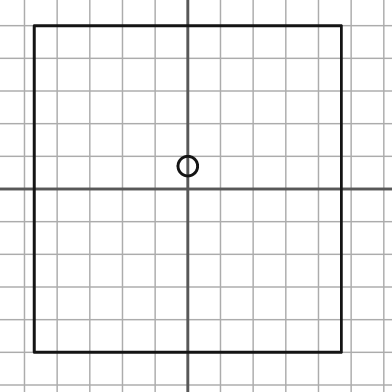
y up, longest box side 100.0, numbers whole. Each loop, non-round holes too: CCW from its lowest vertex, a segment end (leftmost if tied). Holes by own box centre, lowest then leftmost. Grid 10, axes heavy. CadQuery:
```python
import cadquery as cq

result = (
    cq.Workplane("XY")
    .moveTo(-47.0, -50.0)
    .lineTo(47.0, -50.0)
    .lineTo(47.0, 50.0)
    .lineTo(-47.0, 50.0)
    .close()
    .moveTo(0.0, 7.0)
    .circle(3.0)
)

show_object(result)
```